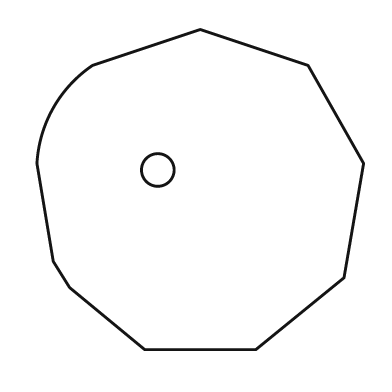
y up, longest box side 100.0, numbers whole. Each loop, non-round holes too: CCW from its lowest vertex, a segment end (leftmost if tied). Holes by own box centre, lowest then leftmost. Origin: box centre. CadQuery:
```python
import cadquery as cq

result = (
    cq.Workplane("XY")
    .moveTo(-17.0, -49.0)
    .lineTo(17.0, -49.0)
    .lineTo(44.0, -27.0)
    .lineTo(50.0, 8.0)
    .lineTo(33.0, 38.0)
    .lineTo(0.0, 49.0)
    .lineTo(-33.0, 38.0)
    .threePointArc((-45.0, 25.0), (-50.0, 8.0))
    .lineTo(-45.0, -22.0)
    .lineTo(-40.0, -30.0)
    .close()
    .moveTo(-13.0, 6.0)
    .circle(5.0)
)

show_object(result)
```